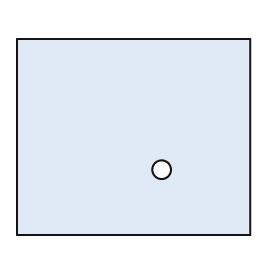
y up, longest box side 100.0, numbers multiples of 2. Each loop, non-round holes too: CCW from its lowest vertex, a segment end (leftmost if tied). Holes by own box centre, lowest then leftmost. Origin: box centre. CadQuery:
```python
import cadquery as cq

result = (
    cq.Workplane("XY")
    .moveTo(-50.0, -42.0)
    .lineTo(50.0, -42.0)
    .lineTo(50.0, 42.0)
    .lineTo(-50.0, 42.0)
    .close()
    .moveTo(12.0, -14.0)
    .circle(4.0)
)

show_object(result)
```